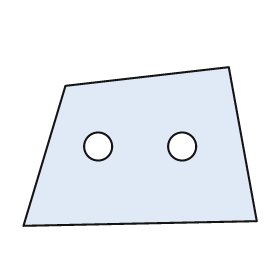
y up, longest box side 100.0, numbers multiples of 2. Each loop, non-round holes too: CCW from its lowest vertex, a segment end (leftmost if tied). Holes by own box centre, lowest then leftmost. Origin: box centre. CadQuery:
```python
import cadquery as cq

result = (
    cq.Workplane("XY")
    .moveTo(-50.0, -34.0)
    .lineTo(50.0, -32.0)
    .lineTo(38.0, 34.0)
    .lineTo(-32.0, 26.0)
    .close()
    .moveTo(-18.0, 0.0)
    .circle(6.0)
    .moveTo(18.0, 0.0)
    .circle(6.0)
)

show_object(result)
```